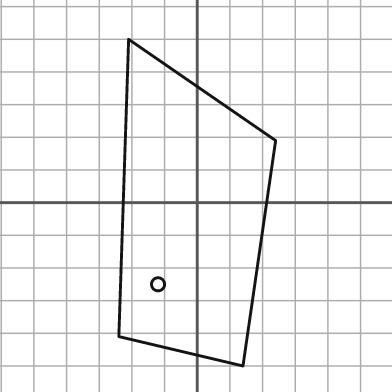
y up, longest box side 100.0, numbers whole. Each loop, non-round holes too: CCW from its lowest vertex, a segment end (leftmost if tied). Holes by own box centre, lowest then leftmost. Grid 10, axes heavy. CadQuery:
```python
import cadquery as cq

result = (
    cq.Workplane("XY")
    .moveTo(14.0, -50.0)
    .lineTo(24.0, 19.0)
    .lineTo(-21.0, 50.0)
    .lineTo(-24.0, -41.0)
    .close()
    .moveTo(-12.0, -25.0)
    .circle(2.0)
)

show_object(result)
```